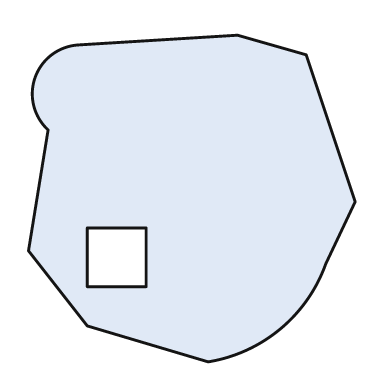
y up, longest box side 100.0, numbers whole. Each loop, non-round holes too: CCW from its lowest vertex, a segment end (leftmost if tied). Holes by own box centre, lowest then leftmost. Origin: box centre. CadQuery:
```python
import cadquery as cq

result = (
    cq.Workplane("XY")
    .moveTo(5.0, -50.0)
    .threePointArc((27.0, -40.0), (41.0, -20.0))
    .lineTo(50.0, -1.0)
    .lineTo(35.0, 44.0)
    .lineTo(14.0, 50.0)
    .lineTo(-35.0, 47.0)
    .threePointArc((-48.0, 37.0), (-44.0, 21.0))
    .lineTo(-50.0, -16.0)
    .lineTo(-32.0, -39.0)
    .close()
    .moveTo(-32.0, -27.0)
    .lineTo(-14.0, -27.0)
    .lineTo(-14.0, -9.0)
    .lineTo(-32.0, -9.0)
    .close()
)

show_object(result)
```